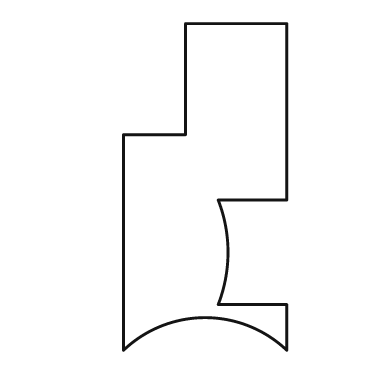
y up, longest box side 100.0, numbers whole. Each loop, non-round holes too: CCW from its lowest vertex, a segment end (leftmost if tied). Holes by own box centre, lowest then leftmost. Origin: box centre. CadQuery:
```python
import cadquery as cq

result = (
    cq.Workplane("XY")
    .moveTo(-25.0, -50.0)
    .threePointArc((0.0, -40.0), (25.0, -50.0))
    .lineTo(25.0, -36.0)
    .lineTo(4.0, -36.0)
    .threePointArc((7.0, -20.0), (4.0, -4.0))
    .lineTo(25.0, -4.0)
    .lineTo(25.0, 50.0)
    .lineTo(-6.0, 50.0)
    .lineTo(-6.0, 16.0)
    .lineTo(-25.0, 16.0)
    .close()
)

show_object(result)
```